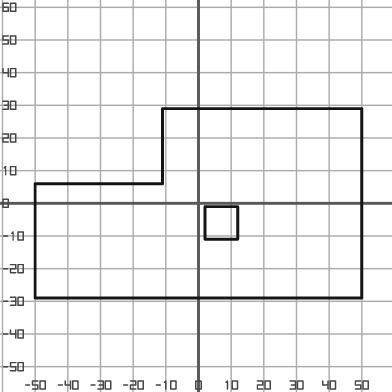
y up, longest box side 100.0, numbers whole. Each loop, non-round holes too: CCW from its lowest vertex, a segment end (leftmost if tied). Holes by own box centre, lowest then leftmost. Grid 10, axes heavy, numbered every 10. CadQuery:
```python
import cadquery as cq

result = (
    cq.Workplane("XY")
    .moveTo(-50.0, -29.0)
    .lineTo(50.0, -29.0)
    .lineTo(50.0, 29.0)
    .lineTo(-11.0, 29.0)
    .lineTo(-11.0, 6.0)
    .lineTo(-50.0, 6.0)
    .close()
    .moveTo(2.0, -11.0)
    .lineTo(12.0, -11.0)
    .lineTo(12.0, -1.0)
    .lineTo(2.0, -1.0)
    .close()
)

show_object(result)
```